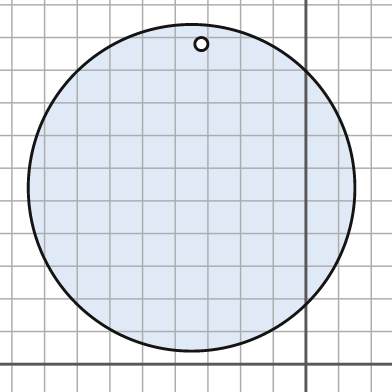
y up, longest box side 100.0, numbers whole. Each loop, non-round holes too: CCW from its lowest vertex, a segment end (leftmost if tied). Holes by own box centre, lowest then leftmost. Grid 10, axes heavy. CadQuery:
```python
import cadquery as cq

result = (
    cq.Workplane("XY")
    .moveTo(-35.0, 54.0)
    .circle(50.0)
    .moveTo(-32.0, 98.0)
    .circle(2.0)
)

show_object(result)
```